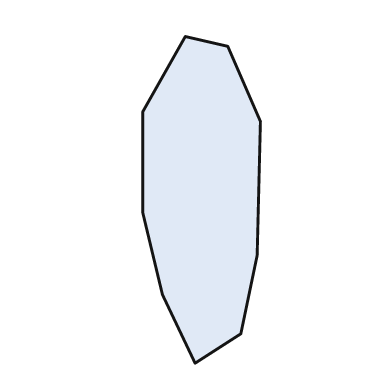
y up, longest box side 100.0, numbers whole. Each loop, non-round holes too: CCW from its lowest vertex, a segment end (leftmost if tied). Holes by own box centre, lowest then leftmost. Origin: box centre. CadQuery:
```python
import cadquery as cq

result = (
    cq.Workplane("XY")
    .moveTo(-2.0, -50.0)
    .lineTo(12.0, -41.0)
    .lineTo(17.0, -17.0)
    .lineTo(18.0, 24.0)
    .lineTo(8.0, 47.0)
    .lineTo(-5.0, 50.0)
    .lineTo(-18.0, 27.0)
    .lineTo(-18.0, -4.0)
    .lineTo(-12.0, -29.0)
    .close()
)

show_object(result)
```